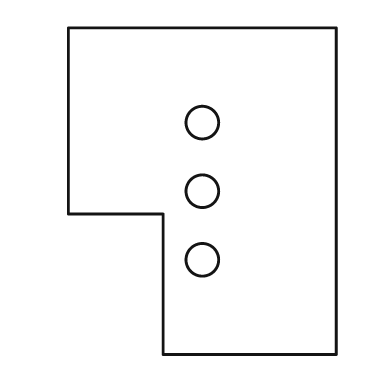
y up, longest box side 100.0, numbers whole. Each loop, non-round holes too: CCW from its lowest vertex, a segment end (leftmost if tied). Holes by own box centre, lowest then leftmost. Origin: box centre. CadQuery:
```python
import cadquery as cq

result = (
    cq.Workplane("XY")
    .moveTo(-12.0, -50.0)
    .lineTo(41.0, -50.0)
    .lineTo(41.0, 50.0)
    .lineTo(-41.0, 50.0)
    .lineTo(-41.0, -7.0)
    .lineTo(-12.0, -7.0)
    .close()
    .moveTo(0.0, -21.0)
    .circle(5.0)
    .moveTo(0.0, 0.0)
    .circle(5.0)
    .moveTo(0.0, 21.0)
    .circle(5.0)
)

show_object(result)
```